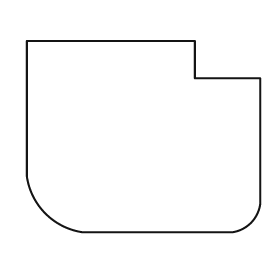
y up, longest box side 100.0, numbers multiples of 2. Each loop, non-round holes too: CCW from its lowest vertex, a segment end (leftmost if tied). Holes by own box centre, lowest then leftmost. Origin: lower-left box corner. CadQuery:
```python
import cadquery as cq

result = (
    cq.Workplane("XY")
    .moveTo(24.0, 0.0)
    .lineTo(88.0, 0.0)
    .threePointArc((96.0, 4.0), (100.0, 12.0))
    .lineTo(100.0, 66.0)
    .lineTo(72.0, 66.0)
    .lineTo(72.0, 82.0)
    .lineTo(0.0, 82.0)
    .lineTo(0.0, 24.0)
    .threePointArc((8.0, 8.0), (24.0, 0.0))
    .close()
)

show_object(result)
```